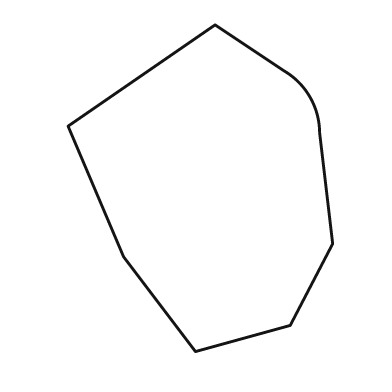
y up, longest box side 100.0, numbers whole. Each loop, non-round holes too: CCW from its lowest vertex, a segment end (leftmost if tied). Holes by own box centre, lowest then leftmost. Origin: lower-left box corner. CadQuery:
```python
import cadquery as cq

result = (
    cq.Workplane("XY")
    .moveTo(39.0, 0.0)
    .lineTo(68.0, 8.0)
    .lineTo(81.0, 33.0)
    .lineTo(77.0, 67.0)
    .threePointArc((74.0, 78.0), (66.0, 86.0))
    .lineTo(45.0, 100.0)
    .lineTo(0.0, 69.0)
    .lineTo(17.0, 29.0)
    .close()
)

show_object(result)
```